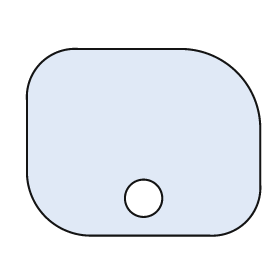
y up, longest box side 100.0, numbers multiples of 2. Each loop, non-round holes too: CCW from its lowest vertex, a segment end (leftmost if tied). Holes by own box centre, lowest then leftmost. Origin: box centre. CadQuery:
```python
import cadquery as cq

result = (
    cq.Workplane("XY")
    .moveTo(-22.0, -40.0)
    .lineTo(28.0, -40.0)
    .threePointArc((44.0, -34.0), (50.0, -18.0))
    .lineTo(50.0, 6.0)
    .threePointArc((40.0, 30.0), (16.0, 40.0))
    .lineTo(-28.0, 40.0)
    .threePointArc((-44.0, 34.0), (-50.0, 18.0))
    .lineTo(-50.0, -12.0)
    .threePointArc((-42.0, -32.0), (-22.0, -40.0))
    .close()
    .moveTo(0.0, -24.0)
    .circle(8.0)
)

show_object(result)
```